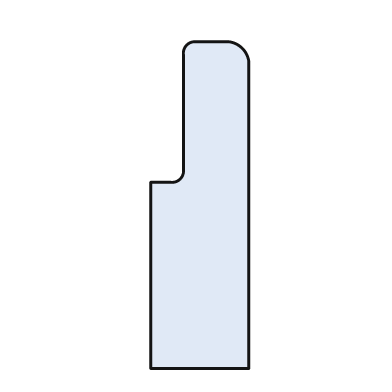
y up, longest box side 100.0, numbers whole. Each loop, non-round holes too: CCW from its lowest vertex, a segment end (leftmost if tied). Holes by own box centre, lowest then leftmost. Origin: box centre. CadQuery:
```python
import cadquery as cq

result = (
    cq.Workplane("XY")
    .moveTo(-15.0, -50.0)
    .lineTo(15.0, -50.0)
    .lineTo(15.0, 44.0)
    .threePointArc((13.0, 48.0), (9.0, 50.0))
    .lineTo(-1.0, 50.0)
    .threePointArc((-4.0, 49.0), (-5.0, 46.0))
    .lineTo(-5.0, 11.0)
    .threePointArc((-6.0, 8.0), (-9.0, 7.0))
    .lineTo(-15.0, 7.0)
    .close()
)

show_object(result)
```